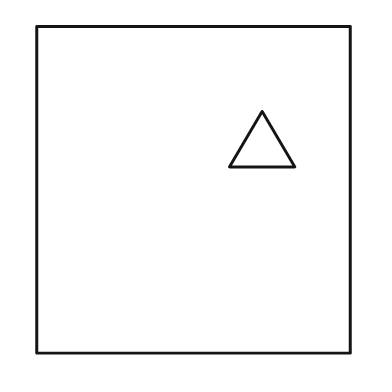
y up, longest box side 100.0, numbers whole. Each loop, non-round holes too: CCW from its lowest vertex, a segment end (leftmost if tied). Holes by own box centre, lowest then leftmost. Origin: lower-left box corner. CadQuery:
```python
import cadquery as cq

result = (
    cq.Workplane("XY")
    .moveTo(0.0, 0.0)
    .lineTo(96.0, 0.0)
    .lineTo(96.0, 100.0)
    .lineTo(0.0, 100.0)
    .close()
    .moveTo(59.0, 57.0)
    .lineTo(79.0, 57.0)
    .lineTo(69.0, 74.0)
    .close()
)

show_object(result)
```